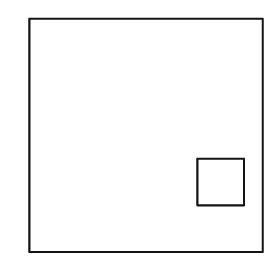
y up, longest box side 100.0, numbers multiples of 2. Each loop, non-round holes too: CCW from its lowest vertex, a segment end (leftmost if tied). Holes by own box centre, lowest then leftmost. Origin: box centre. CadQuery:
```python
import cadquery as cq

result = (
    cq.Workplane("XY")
    .moveTo(-50.0, -50.0)
    .lineTo(50.0, -50.0)
    .lineTo(50.0, 50.0)
    .lineTo(-50.0, 50.0)
    .close()
    .moveTo(22.0, -30.0)
    .lineTo(42.0, -30.0)
    .lineTo(42.0, -10.0)
    .lineTo(22.0, -10.0)
    .close()
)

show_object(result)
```